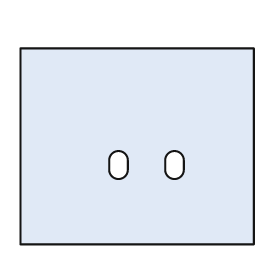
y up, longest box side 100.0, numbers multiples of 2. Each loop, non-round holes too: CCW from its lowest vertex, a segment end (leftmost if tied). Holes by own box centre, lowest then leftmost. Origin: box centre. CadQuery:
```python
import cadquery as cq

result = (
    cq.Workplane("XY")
    .moveTo(-50.0, -42.0)
    .lineTo(50.0, -42.0)
    .lineTo(50.0, 42.0)
    .lineTo(-50.0, 42.0)
    .close()
    .moveTo(-12.0, -10.0)
    .threePointArc((-8.0, -14.0), (-4.0, -10.0))
    .lineTo(-4.0, -6.0)
    .threePointArc((-8.0, -2.0), (-12.0, -6.0))
    .close()
    .moveTo(12.0, -10.0)
    .threePointArc((16.0, -14.0), (20.0, -10.0))
    .lineTo(20.0, -6.0)
    .threePointArc((16.0, -2.0), (12.0, -6.0))
    .close()
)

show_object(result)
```